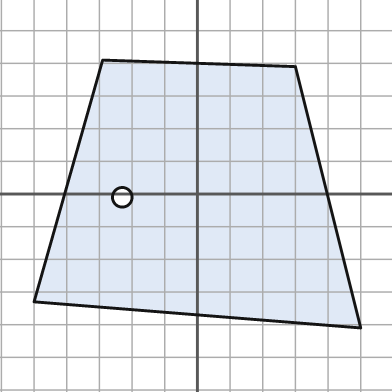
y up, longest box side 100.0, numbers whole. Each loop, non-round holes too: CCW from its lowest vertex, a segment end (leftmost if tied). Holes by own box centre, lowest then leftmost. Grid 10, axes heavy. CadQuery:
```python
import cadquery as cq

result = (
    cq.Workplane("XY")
    .moveTo(50.0, -41.0)
    .lineTo(30.0, 39.0)
    .lineTo(-29.0, 41.0)
    .lineTo(-50.0, -33.0)
    .close()
    .moveTo(-23.0, -1.0)
    .circle(3.0)
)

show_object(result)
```